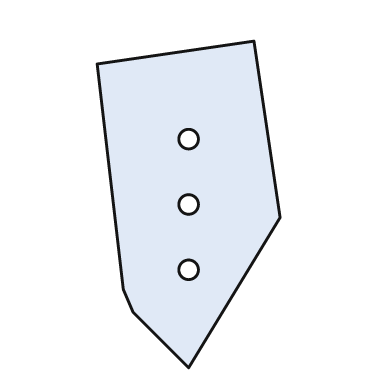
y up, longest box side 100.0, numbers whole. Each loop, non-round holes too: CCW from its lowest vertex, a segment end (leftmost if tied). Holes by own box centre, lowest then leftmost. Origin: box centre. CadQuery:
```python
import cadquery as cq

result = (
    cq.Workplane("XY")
    .moveTo(0.0, -50.0)
    .lineTo(28.0, -4.0)
    .lineTo(20.0, 50.0)
    .lineTo(-28.0, 43.0)
    .lineTo(-20.0, -26.0)
    .lineTo(-17.0, -33.0)
    .close()
    .moveTo(0.0, -20.0)
    .circle(3.0)
    .moveTo(0.0, 0.0)
    .circle(3.0)
    .moveTo(0.0, 20.0)
    .circle(3.0)
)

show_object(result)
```